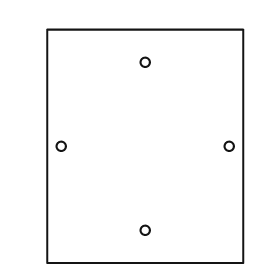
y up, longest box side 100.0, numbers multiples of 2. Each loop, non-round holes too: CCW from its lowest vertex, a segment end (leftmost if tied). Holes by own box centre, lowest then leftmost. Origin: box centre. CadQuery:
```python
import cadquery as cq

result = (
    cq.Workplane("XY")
    .moveTo(-42.0, -50.0)
    .lineTo(42.0, -50.0)
    .lineTo(42.0, 50.0)
    .lineTo(-42.0, 50.0)
    .close()
    .moveTo(0.0, -36.0)
    .circle(2.0)
    .moveTo(-36.0, 0.0)
    .circle(2.0)
    .moveTo(36.0, 0.0)
    .circle(2.0)
    .moveTo(0.0, 36.0)
    .circle(2.0)
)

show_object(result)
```